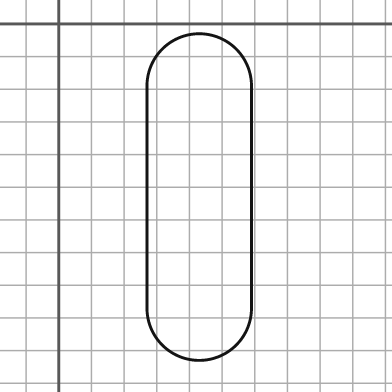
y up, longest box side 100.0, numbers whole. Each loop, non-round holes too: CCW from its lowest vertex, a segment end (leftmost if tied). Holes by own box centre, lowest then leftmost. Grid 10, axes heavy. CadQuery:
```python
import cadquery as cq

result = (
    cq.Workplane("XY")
    .moveTo(27.0, -87.0)
    .threePointArc((43.0, -103.0), (59.0, -87.0))
    .lineTo(59.0, -19.0)
    .threePointArc((43.0, -3.0), (27.0, -19.0))
    .close()
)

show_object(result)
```